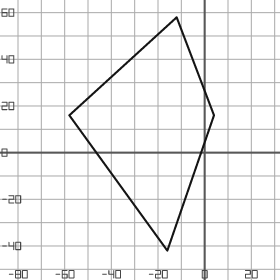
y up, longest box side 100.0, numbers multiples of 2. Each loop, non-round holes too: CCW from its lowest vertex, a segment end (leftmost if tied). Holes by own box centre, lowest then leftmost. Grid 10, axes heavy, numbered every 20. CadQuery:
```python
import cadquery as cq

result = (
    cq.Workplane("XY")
    .moveTo(-16.0, -42.0)
    .lineTo(4.0, 16.0)
    .lineTo(-12.0, 58.0)
    .lineTo(-58.0, 16.0)
    .close()
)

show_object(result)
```